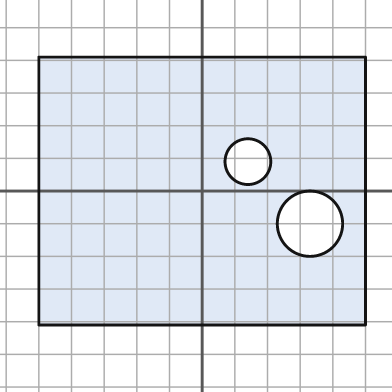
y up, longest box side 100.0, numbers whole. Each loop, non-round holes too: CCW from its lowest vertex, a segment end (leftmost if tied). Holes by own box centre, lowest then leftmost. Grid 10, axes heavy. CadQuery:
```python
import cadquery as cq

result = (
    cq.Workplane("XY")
    .moveTo(-50.0, -41.0)
    .lineTo(50.0, -41.0)
    .lineTo(50.0, 41.0)
    .lineTo(-50.0, 41.0)
    .close()
    .moveTo(33.0, -10.0)
    .circle(10.0)
    .moveTo(14.0, 9.0)
    .circle(7.0)
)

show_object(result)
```